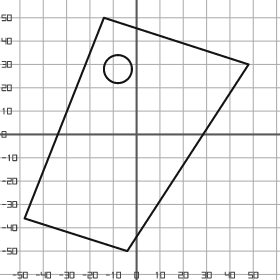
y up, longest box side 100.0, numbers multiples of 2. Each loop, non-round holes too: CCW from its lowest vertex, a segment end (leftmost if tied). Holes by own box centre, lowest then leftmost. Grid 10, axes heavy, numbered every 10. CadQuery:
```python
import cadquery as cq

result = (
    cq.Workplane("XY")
    .moveTo(-4.0, -50.0)
    .lineTo(48.0, 30.0)
    .lineTo(-14.0, 50.0)
    .lineTo(-48.0, -36.0)
    .close()
    .moveTo(-8.0, 28.0)
    .circle(6.0)
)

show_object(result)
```